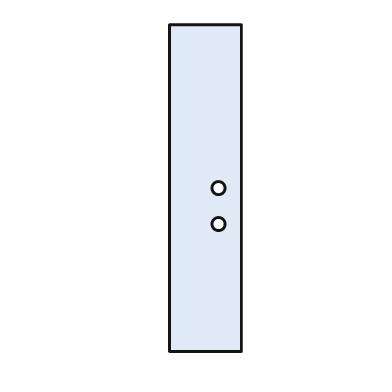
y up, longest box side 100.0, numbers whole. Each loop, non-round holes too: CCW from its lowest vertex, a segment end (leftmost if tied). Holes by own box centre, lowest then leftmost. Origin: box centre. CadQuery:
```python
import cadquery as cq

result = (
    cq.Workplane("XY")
    .moveTo(-11.0, -50.0)
    .lineTo(11.0, -50.0)
    .lineTo(11.0, 50.0)
    .lineTo(-11.0, 50.0)
    .close()
    .moveTo(4.0, -11.0)
    .circle(2.0)
    .moveTo(4.0, 0.0)
    .circle(2.0)
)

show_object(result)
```